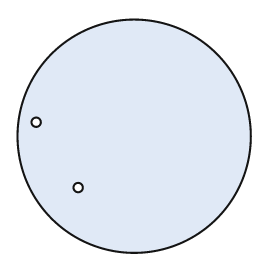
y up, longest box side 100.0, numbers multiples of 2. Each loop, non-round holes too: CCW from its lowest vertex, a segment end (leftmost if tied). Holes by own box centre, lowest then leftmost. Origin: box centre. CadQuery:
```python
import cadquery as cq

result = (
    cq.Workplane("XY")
    .moveTo(0.0, 0.0)
    .circle(50.0)
    .moveTo(-24.0, -22.0)
    .circle(2.0)
    .moveTo(-42.0, 6.0)
    .circle(2.0)
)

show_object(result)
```